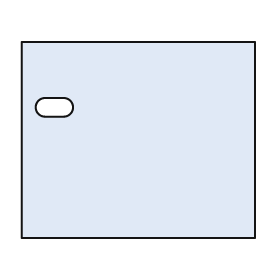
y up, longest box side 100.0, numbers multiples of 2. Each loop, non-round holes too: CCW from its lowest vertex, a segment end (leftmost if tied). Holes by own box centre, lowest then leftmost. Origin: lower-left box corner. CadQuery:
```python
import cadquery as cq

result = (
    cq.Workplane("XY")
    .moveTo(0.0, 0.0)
    .lineTo(100.0, 0.0)
    .lineTo(100.0, 84.0)
    .lineTo(0.0, 84.0)
    .close()
    .moveTo(10.0, 52.0)
    .lineTo(18.0, 52.0)
    .threePointArc((22.0, 56.0), (18.0, 60.0))
    .lineTo(10.0, 60.0)
    .threePointArc((6.0, 56.0), (10.0, 52.0))
    .close()
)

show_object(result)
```